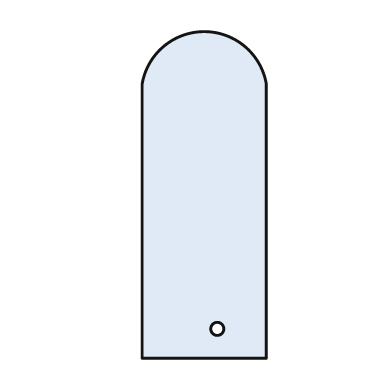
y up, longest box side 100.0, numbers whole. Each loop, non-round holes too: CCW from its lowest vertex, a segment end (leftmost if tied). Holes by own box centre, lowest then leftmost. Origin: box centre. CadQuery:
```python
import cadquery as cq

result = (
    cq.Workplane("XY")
    .moveTo(-19.0, -50.0)
    .lineTo(19.0, -50.0)
    .lineTo(19.0, 34.0)
    .threePointArc((0.0, 50.0), (-19.0, 34.0))
    .close()
    .moveTo(4.0, -41.0)
    .circle(2.0)
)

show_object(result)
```